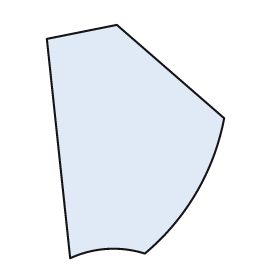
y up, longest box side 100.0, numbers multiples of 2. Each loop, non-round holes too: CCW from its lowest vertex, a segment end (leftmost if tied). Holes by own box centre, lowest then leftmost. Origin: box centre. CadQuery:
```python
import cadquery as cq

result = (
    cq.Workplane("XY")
    .moveTo(-28.0, -50.0)
    .threePointArc((-12.0, -46.0), (4.0, -48.0))
    .threePointArc((26.0, -22.0), (38.0, 10.0))
    .lineTo(-8.0, 50.0)
    .lineTo(-38.0, 44.0)
    .close()
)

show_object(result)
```